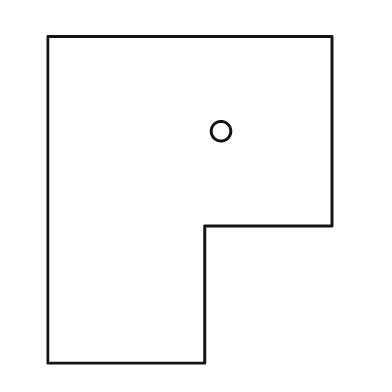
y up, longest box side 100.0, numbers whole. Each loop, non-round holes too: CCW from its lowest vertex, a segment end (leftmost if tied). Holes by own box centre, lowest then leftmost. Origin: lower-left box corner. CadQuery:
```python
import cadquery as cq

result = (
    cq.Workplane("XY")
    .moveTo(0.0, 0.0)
    .lineTo(48.0, 0.0)
    .lineTo(48.0, 42.0)
    .lineTo(87.0, 42.0)
    .lineTo(87.0, 100.0)
    .lineTo(0.0, 100.0)
    .close()
    .moveTo(53.0, 71.0)
    .circle(3.0)
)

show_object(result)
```